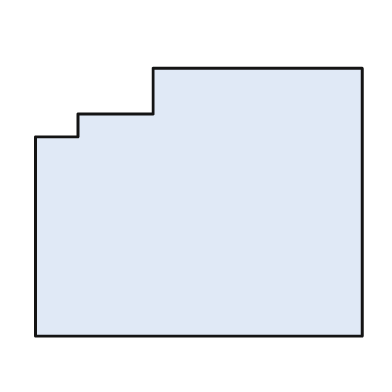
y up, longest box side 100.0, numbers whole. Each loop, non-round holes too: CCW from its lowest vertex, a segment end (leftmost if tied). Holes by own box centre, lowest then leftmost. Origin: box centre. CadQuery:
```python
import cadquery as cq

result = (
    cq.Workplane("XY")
    .moveTo(-50.0, -41.0)
    .lineTo(50.0, -41.0)
    .lineTo(50.0, 41.0)
    .lineTo(-14.0, 41.0)
    .lineTo(-14.0, 27.0)
    .lineTo(-37.0, 27.0)
    .lineTo(-37.0, 20.0)
    .lineTo(-50.0, 20.0)
    .close()
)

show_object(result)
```